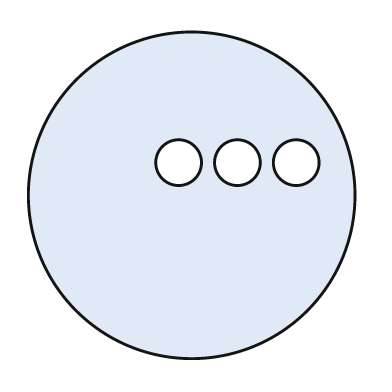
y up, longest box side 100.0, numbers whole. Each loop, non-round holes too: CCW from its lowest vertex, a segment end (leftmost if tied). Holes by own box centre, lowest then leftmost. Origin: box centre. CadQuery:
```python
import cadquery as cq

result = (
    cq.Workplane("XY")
    .moveTo(0.0, 0.0)
    .circle(50.0)
    .moveTo(-4.0, 10.0)
    .circle(7.0)
    .moveTo(14.0, 10.0)
    .circle(7.0)
    .moveTo(32.0, 10.0)
    .circle(7.0)
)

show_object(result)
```